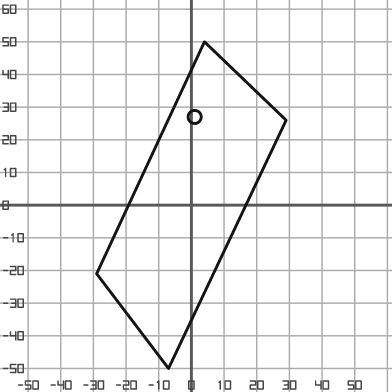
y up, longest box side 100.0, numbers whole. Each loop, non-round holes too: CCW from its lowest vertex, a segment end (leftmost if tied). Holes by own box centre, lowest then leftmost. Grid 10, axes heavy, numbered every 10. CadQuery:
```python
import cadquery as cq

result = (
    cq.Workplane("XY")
    .moveTo(-7.0, -50.0)
    .lineTo(29.0, 26.0)
    .lineTo(4.0, 50.0)
    .lineTo(-29.0, -21.0)
    .close()
    .moveTo(1.0, 27.0)
    .circle(2.0)
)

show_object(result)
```